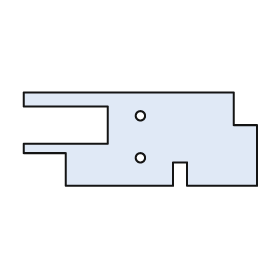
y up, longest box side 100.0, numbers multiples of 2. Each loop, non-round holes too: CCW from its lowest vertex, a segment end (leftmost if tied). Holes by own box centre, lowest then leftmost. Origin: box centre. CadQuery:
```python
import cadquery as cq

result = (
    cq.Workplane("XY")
    .moveTo(-32.0, -20.0)
    .lineTo(14.0, -20.0)
    .lineTo(14.0, -10.0)
    .lineTo(20.0, -10.0)
    .lineTo(20.0, -20.0)
    .lineTo(50.0, -20.0)
    .lineTo(50.0, 6.0)
    .lineTo(40.0, 6.0)
    .lineTo(40.0, 20.0)
    .lineTo(-50.0, 20.0)
    .lineTo(-50.0, 14.0)
    .lineTo(-14.0, 14.0)
    .lineTo(-14.0, -2.0)
    .lineTo(-50.0, -2.0)
    .lineTo(-50.0, -6.0)
    .lineTo(-32.0, -6.0)
    .close()
    .moveTo(0.0, -8.0)
    .circle(2.0)
    .moveTo(0.0, 10.0)
    .circle(2.0)
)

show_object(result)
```